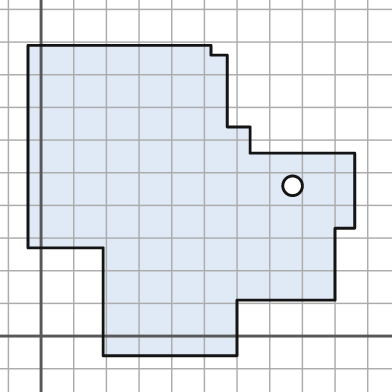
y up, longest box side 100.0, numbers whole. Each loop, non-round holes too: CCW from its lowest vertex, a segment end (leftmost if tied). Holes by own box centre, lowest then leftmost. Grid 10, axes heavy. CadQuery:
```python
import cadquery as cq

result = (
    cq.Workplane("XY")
    .moveTo(19.0, -6.0)
    .lineTo(60.0, -6.0)
    .lineTo(60.0, 11.0)
    .lineTo(90.0, 11.0)
    .lineTo(90.0, 33.0)
    .lineTo(96.0, 33.0)
    .lineTo(96.0, 56.0)
    .lineTo(64.0, 56.0)
    .lineTo(64.0, 64.0)
    .lineTo(57.0, 64.0)
    .lineTo(57.0, 86.0)
    .lineTo(52.0, 86.0)
    .lineTo(52.0, 89.0)
    .lineTo(-4.0, 89.0)
    .lineTo(-4.0, 27.0)
    .lineTo(19.0, 27.0)
    .close()
    .moveTo(77.0, 46.0)
    .circle(3.0)
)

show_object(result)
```